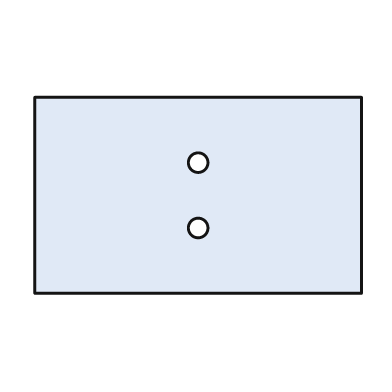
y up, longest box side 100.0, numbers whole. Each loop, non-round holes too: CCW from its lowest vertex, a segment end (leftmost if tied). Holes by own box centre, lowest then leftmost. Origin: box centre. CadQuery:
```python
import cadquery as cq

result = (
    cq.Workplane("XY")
    .moveTo(-50.0, -30.0)
    .lineTo(50.0, -30.0)
    .lineTo(50.0, 30.0)
    .lineTo(-50.0, 30.0)
    .close()
    .moveTo(0.0, -10.0)
    .circle(3.0)
    .moveTo(0.0, 10.0)
    .circle(3.0)
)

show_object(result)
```